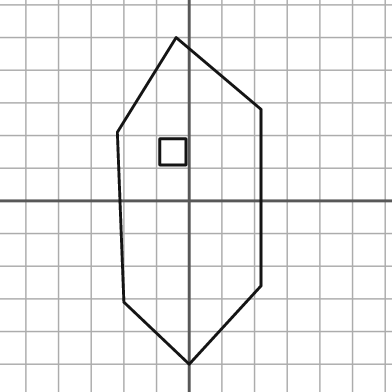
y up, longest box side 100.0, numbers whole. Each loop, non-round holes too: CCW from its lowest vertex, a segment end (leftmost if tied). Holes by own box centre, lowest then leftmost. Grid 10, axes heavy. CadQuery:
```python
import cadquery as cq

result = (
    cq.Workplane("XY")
    .moveTo(0.0, -50.0)
    .lineTo(22.0, -26.0)
    .lineTo(22.0, 28.0)
    .lineTo(-4.0, 50.0)
    .lineTo(-22.0, 21.0)
    .lineTo(-20.0, -31.0)
    .close()
    .moveTo(-9.0, 11.0)
    .lineTo(-1.0, 11.0)
    .lineTo(-1.0, 19.0)
    .lineTo(-9.0, 19.0)
    .close()
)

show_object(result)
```